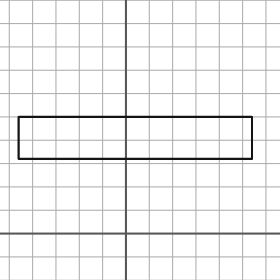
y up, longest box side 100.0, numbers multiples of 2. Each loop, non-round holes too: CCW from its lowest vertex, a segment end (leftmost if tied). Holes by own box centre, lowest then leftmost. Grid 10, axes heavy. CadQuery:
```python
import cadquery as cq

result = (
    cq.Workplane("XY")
    .moveTo(-46.0, 32.0)
    .lineTo(54.0, 32.0)
    .lineTo(54.0, 50.0)
    .lineTo(-46.0, 50.0)
    .close()
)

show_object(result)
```